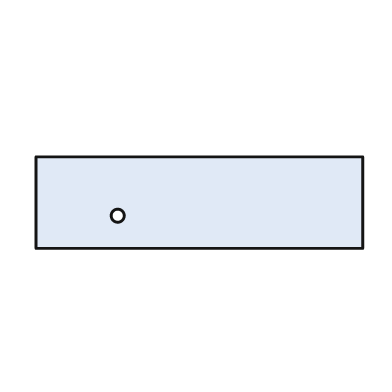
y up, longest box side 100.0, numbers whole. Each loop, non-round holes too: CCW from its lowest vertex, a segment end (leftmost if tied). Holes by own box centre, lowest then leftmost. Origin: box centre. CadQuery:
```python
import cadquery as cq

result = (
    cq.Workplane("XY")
    .moveTo(-50.0, -14.0)
    .lineTo(50.0, -14.0)
    .lineTo(50.0, 14.0)
    .lineTo(-50.0, 14.0)
    .close()
    .moveTo(-25.0, -4.0)
    .circle(2.0)
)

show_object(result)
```